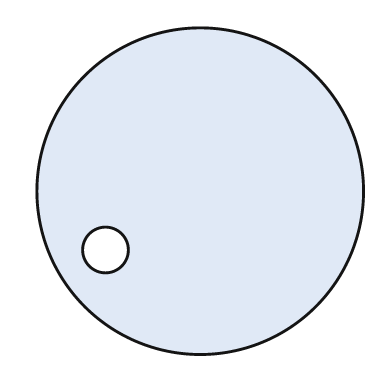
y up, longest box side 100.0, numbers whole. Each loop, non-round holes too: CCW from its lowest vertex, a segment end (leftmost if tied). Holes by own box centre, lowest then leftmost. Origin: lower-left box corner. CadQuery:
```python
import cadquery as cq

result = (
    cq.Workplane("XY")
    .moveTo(50.0, 50.0)
    .circle(50.0)
    .moveTo(21.0, 32.0)
    .circle(7.0)
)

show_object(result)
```